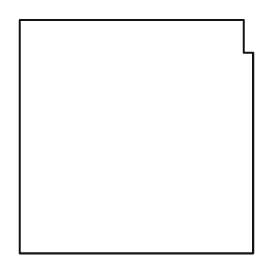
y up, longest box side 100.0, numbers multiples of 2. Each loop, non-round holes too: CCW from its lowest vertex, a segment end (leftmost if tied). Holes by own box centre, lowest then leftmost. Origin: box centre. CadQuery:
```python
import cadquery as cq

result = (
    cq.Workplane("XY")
    .moveTo(-50.0, -50.0)
    .lineTo(50.0, -50.0)
    .lineTo(50.0, 36.0)
    .lineTo(46.0, 36.0)
    .lineTo(46.0, 50.0)
    .lineTo(-50.0, 50.0)
    .close()
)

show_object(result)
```